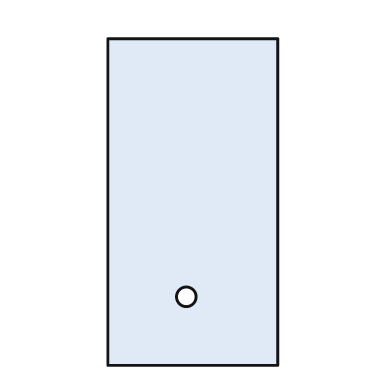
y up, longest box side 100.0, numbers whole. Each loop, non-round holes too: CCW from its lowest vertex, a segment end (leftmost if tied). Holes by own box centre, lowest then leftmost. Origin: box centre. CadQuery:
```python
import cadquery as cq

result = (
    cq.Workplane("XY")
    .moveTo(-26.0, -50.0)
    .lineTo(26.0, -50.0)
    .lineTo(26.0, 50.0)
    .lineTo(-26.0, 50.0)
    .close()
    .moveTo(-2.0, -29.0)
    .circle(3.0)
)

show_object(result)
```